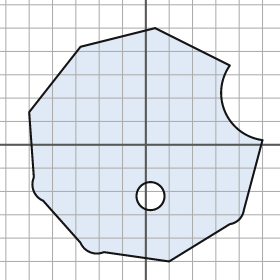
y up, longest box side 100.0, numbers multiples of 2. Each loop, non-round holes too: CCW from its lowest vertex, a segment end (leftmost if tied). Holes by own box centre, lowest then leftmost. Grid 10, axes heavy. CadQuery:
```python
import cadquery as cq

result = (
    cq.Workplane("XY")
    .moveTo(10.0, -50.0)
    .lineTo(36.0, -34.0)
    .threePointArc((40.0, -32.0), (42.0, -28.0))
    .lineTo(50.0, 2.0)
    .threePointArc((34.0, 14.0), (36.0, 34.0))
    .lineTo(4.0, 50.0)
    .lineTo(-28.0, 42.0)
    .lineTo(-50.0, 14.0)
    .lineTo(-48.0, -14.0)
    .threePointArc((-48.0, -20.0), (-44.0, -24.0))
    .lineTo(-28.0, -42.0)
    .threePointArc((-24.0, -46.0), (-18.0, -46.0))
    .close()
    .moveTo(2.0, -22.0)
    .circle(6.0)
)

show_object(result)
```